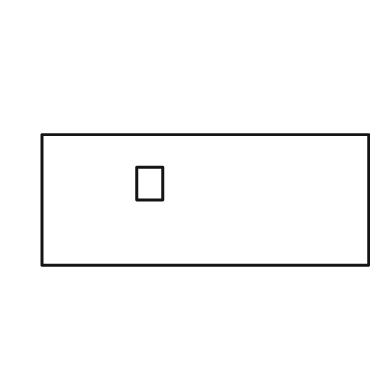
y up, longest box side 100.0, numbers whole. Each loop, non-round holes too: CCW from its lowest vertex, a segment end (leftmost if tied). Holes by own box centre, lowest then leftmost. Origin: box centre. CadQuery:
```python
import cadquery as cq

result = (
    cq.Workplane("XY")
    .moveTo(-50.0, -20.0)
    .lineTo(50.0, -20.0)
    .lineTo(50.0, 20.0)
    .lineTo(-50.0, 20.0)
    .close()
    .moveTo(-21.0, 0.0)
    .lineTo(-13.0, 0.0)
    .lineTo(-13.0, 10.0)
    .lineTo(-21.0, 10.0)
    .close()
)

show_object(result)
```